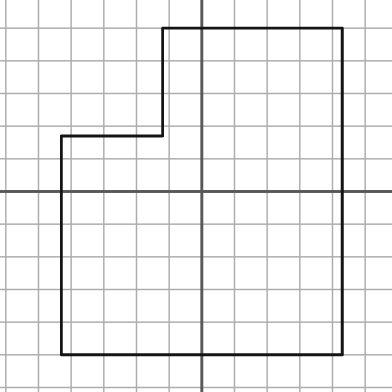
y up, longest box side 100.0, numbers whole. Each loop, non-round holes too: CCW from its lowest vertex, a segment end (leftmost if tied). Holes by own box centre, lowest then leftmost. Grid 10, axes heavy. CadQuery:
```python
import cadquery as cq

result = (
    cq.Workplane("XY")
    .moveTo(-43.0, -50.0)
    .lineTo(43.0, -50.0)
    .lineTo(43.0, 50.0)
    .lineTo(-12.0, 50.0)
    .lineTo(-12.0, 17.0)
    .lineTo(-43.0, 17.0)
    .close()
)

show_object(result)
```